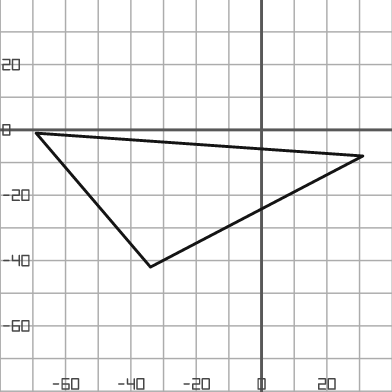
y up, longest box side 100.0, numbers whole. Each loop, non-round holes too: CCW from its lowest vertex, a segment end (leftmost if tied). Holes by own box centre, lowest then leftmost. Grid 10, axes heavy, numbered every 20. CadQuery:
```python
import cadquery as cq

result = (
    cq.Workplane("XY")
    .moveTo(-34.0, -42.0)
    .lineTo(31.0, -8.0)
    .lineTo(-69.0, -1.0)
    .close()
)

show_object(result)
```